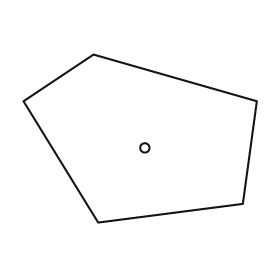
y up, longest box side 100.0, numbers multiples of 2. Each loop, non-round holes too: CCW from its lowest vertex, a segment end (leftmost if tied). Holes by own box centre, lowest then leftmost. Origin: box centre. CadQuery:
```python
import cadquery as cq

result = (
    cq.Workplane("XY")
    .moveTo(-18.0, -36.0)
    .lineTo(44.0, -28.0)
    .lineTo(50.0, 16.0)
    .lineTo(-20.0, 36.0)
    .lineTo(-50.0, 16.0)
    .close()
    .moveTo(2.0, -4.0)
    .circle(2.0)
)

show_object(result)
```